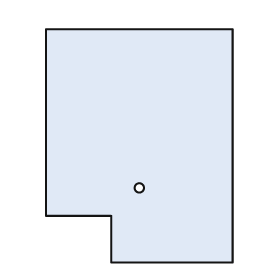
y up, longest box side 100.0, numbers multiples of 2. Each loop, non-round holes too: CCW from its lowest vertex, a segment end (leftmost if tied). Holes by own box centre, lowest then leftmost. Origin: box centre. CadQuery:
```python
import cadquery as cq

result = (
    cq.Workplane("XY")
    .moveTo(-12.0, -50.0)
    .lineTo(40.0, -50.0)
    .lineTo(40.0, 50.0)
    .lineTo(-40.0, 50.0)
    .lineTo(-40.0, -30.0)
    .lineTo(-12.0, -30.0)
    .close()
    .moveTo(0.0, -18.0)
    .circle(2.0)
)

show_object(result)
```